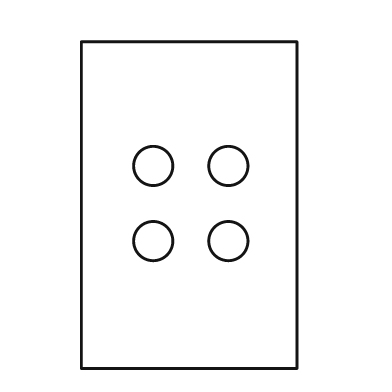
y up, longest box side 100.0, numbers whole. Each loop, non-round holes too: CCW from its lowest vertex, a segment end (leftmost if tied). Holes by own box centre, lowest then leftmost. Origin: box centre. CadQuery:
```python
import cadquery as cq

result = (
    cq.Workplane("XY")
    .moveTo(-33.0, -50.0)
    .lineTo(33.0, -50.0)
    .lineTo(33.0, 50.0)
    .lineTo(-33.0, 50.0)
    .close()
    .moveTo(-11.0, -11.0)
    .circle(6.0)
    .moveTo(12.0, -11.0)
    .circle(6.0)
    .moveTo(-11.0, 12.0)
    .circle(6.0)
    .moveTo(12.0, 12.0)
    .circle(6.0)
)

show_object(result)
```